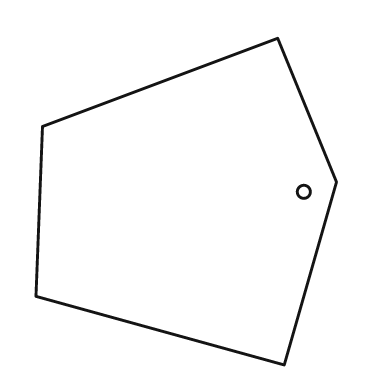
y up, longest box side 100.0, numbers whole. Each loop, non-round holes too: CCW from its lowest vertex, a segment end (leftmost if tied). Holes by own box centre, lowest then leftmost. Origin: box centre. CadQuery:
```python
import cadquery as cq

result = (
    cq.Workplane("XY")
    .moveTo(30.0, -50.0)
    .lineTo(46.0, 6.0)
    .lineTo(28.0, 50.0)
    .lineTo(-44.0, 23.0)
    .lineTo(-46.0, -29.0)
    .close()
    .moveTo(36.0, 3.0)
    .circle(2.0)
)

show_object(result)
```